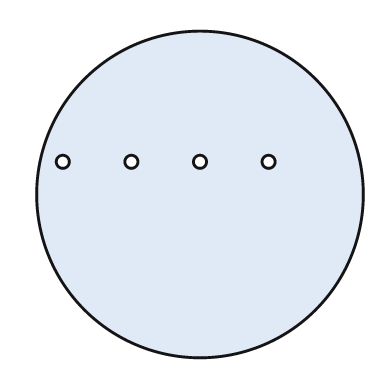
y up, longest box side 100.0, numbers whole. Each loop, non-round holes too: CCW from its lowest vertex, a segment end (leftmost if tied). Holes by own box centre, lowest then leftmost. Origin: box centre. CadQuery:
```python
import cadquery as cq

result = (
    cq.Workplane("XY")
    .moveTo(0.0, 0.0)
    .circle(50.0)
    .moveTo(-42.0, 10.0)
    .circle(2.0)
    .moveTo(-21.0, 10.0)
    .circle(2.0)
    .moveTo(0.0, 10.0)
    .circle(2.0)
    .moveTo(21.0, 10.0)
    .circle(2.0)
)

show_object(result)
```